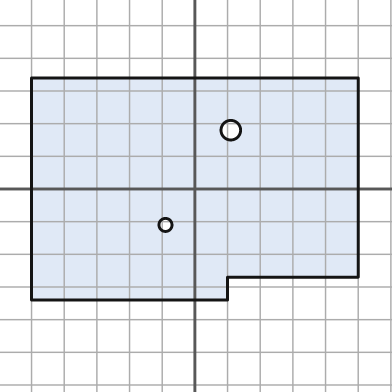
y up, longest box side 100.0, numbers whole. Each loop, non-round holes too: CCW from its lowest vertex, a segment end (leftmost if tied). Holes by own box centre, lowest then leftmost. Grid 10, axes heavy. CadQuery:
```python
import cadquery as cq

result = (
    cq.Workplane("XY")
    .moveTo(-50.0, -34.0)
    .lineTo(10.0, -34.0)
    .lineTo(10.0, -27.0)
    .lineTo(50.0, -27.0)
    .lineTo(50.0, 34.0)
    .lineTo(-50.0, 34.0)
    .close()
    .moveTo(-9.0, -11.0)
    .circle(2.0)
    .moveTo(11.0, 18.0)
    .circle(3.0)
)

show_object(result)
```